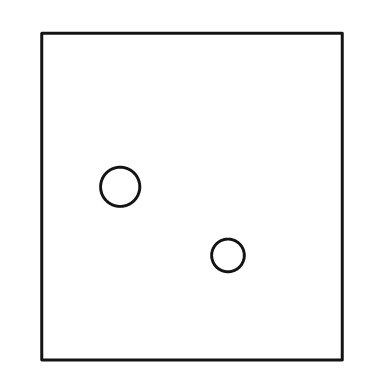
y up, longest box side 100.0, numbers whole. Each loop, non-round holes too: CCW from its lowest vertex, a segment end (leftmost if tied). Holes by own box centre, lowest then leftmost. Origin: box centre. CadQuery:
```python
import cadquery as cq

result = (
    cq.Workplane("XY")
    .moveTo(-46.0, -50.0)
    .lineTo(46.0, -50.0)
    .lineTo(46.0, 50.0)
    .lineTo(-46.0, 50.0)
    .close()
    .moveTo(11.0, -18.0)
    .circle(5.0)
    .moveTo(-22.0, 3.0)
    .circle(6.0)
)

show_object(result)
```